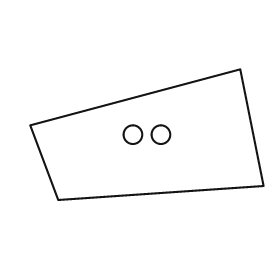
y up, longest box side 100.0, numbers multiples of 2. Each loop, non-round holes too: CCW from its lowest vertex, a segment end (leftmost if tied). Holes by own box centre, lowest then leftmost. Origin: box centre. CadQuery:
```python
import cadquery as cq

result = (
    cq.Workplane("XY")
    .moveTo(-38.0, -28.0)
    .lineTo(50.0, -22.0)
    .lineTo(40.0, 28.0)
    .lineTo(-50.0, 4.0)
    .close()
    .moveTo(-6.0, 0.0)
    .circle(4.0)
    .moveTo(6.0, 0.0)
    .circle(4.0)
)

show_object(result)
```